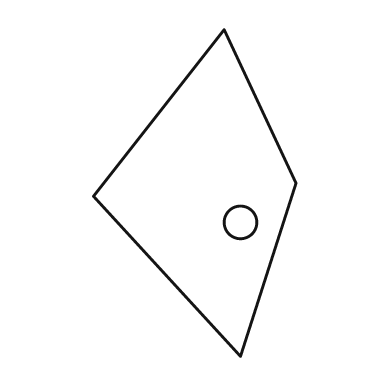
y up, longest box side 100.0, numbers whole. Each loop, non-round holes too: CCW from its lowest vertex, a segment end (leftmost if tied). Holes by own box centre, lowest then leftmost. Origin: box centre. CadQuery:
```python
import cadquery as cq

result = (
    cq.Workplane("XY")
    .moveTo(14.0, -50.0)
    .lineTo(31.0, 3.0)
    .lineTo(9.0, 50.0)
    .lineTo(-31.0, -1.0)
    .close()
    .moveTo(14.0, -9.0)
    .circle(5.0)
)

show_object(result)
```